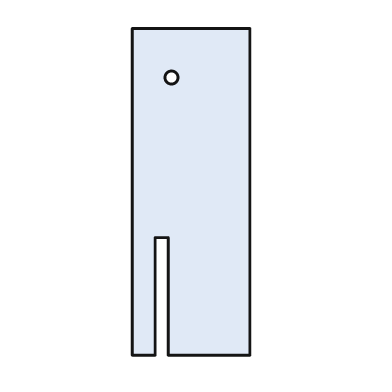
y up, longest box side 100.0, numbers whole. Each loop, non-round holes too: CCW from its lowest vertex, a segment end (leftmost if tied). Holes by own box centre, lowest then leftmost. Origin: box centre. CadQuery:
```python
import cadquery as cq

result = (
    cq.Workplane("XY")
    .moveTo(-18.0, -50.0)
    .lineTo(-11.0, -50.0)
    .lineTo(-11.0, -14.0)
    .lineTo(-7.0, -14.0)
    .lineTo(-7.0, -50.0)
    .lineTo(18.0, -50.0)
    .lineTo(18.0, 50.0)
    .lineTo(-18.0, 50.0)
    .close()
    .moveTo(-6.0, 35.0)
    .circle(2.0)
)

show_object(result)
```